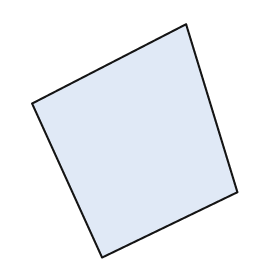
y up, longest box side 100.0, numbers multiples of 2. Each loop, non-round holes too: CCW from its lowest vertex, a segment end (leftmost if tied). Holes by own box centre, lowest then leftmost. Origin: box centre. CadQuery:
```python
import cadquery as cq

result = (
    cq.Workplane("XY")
    .moveTo(-14.0, -50.0)
    .lineTo(44.0, -22.0)
    .lineTo(22.0, 50.0)
    .lineTo(-44.0, 16.0)
    .close()
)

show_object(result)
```